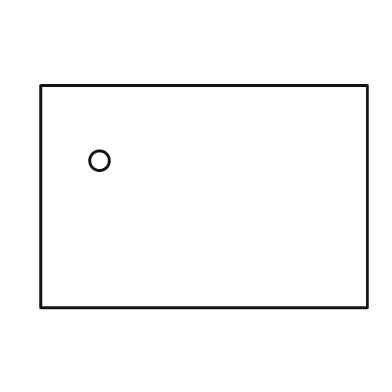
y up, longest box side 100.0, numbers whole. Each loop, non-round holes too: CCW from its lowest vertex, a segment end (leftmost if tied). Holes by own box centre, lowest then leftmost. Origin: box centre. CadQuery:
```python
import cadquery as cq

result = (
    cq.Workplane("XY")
    .moveTo(-50.0, -34.0)
    .lineTo(50.0, -34.0)
    .lineTo(50.0, 34.0)
    .lineTo(-50.0, 34.0)
    .close()
    .moveTo(-32.0, 11.0)
    .circle(3.0)
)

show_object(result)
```